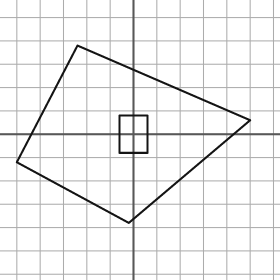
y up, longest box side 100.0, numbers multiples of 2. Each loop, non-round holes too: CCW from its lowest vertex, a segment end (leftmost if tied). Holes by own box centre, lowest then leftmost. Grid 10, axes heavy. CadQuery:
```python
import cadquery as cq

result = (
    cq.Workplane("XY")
    .moveTo(-2.0, -38.0)
    .lineTo(50.0, 6.0)
    .lineTo(-24.0, 38.0)
    .lineTo(-50.0, -12.0)
    .close()
    .moveTo(-6.0, -8.0)
    .lineTo(6.0, -8.0)
    .lineTo(6.0, 8.0)
    .lineTo(-6.0, 8.0)
    .close()
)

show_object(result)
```